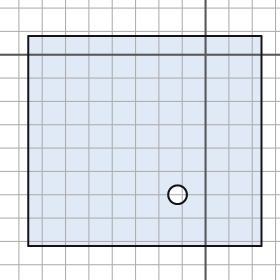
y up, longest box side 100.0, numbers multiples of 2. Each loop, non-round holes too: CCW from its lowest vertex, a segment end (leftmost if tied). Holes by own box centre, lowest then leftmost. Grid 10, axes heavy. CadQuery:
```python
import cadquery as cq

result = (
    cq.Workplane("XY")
    .moveTo(-76.0, -82.0)
    .lineTo(24.0, -82.0)
    .lineTo(24.0, 8.0)
    .lineTo(-76.0, 8.0)
    .close()
    .moveTo(-12.0, -60.0)
    .circle(4.0)
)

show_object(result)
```